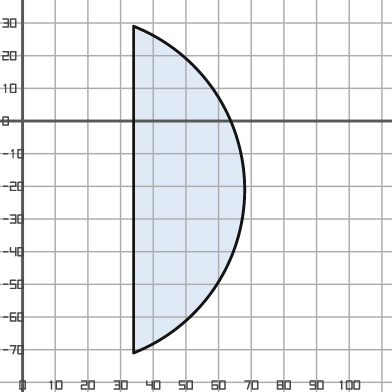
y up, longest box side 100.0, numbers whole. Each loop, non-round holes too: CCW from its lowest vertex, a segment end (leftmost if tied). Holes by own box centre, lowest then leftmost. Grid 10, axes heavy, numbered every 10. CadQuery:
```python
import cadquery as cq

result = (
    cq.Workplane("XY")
    .moveTo(34.0, -71.0)
    .threePointArc((68.0, -21.0), (34.0, 29.0))
    .close()
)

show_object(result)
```